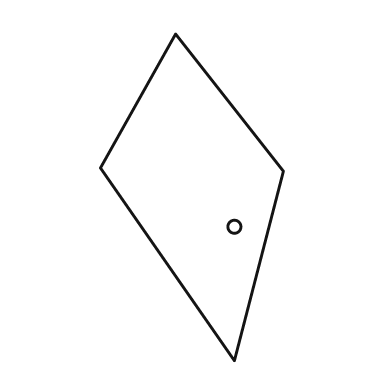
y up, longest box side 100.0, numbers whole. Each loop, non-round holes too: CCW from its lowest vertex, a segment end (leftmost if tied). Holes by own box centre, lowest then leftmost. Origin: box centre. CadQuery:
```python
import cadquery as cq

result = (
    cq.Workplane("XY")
    .moveTo(13.0, -50.0)
    .lineTo(28.0, 8.0)
    .lineTo(-5.0, 50.0)
    .lineTo(-28.0, 9.0)
    .close()
    .moveTo(13.0, -9.0)
    .circle(2.0)
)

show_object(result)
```